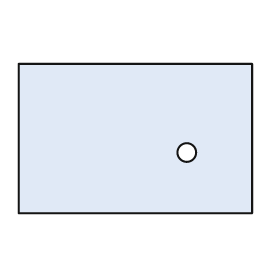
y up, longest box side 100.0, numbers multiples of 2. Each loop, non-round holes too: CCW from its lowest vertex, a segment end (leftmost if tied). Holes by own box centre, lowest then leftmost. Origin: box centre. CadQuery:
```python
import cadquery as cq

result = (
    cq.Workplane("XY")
    .moveTo(-50.0, -32.0)
    .lineTo(50.0, -32.0)
    .lineTo(50.0, 32.0)
    .lineTo(-50.0, 32.0)
    .close()
    .moveTo(22.0, -6.0)
    .circle(4.0)
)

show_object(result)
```